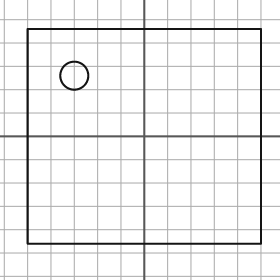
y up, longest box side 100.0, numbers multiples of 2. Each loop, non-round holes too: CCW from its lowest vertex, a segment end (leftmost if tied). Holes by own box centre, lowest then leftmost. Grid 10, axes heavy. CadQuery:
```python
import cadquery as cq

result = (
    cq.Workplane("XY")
    .moveTo(-50.0, -46.0)
    .lineTo(50.0, -46.0)
    .lineTo(50.0, 46.0)
    .lineTo(-50.0, 46.0)
    .close()
    .moveTo(-30.0, 26.0)
    .circle(6.0)
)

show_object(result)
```